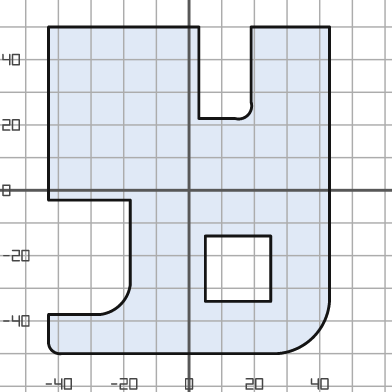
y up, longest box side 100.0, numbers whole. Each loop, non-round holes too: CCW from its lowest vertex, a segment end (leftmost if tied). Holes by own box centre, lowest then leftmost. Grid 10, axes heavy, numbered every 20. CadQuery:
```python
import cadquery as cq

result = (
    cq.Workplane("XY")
    .moveTo(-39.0, -50.0)
    .lineTo(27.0, -50.0)
    .threePointArc((38.0, -45.0), (43.0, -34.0))
    .lineTo(43.0, 50.0)
    .lineTo(19.0, 50.0)
    .lineTo(19.0, 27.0)
    .threePointArc((18.0, 23.0), (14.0, 22.0))
    .lineTo(3.0, 22.0)
    .lineTo(3.0, 50.0)
    .lineTo(-43.0, 50.0)
    .lineTo(-43.0, -3.0)
    .lineTo(-18.0, -3.0)
    .lineTo(-18.0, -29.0)
    .threePointArc((-21.0, -35.0), (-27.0, -38.0))
    .lineTo(-43.0, -38.0)
    .lineTo(-43.0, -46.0)
    .threePointArc((-42.0, -49.0), (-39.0, -50.0))
    .close()
    .moveTo(5.0, -34.0)
    .lineTo(25.0, -34.0)
    .lineTo(25.0, -14.0)
    .lineTo(5.0, -14.0)
    .close()
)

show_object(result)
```